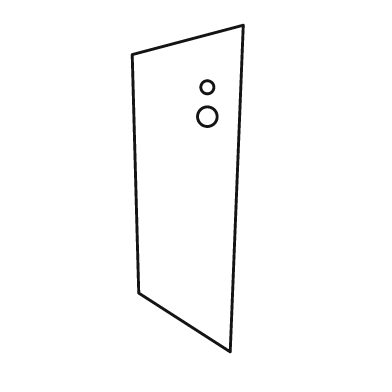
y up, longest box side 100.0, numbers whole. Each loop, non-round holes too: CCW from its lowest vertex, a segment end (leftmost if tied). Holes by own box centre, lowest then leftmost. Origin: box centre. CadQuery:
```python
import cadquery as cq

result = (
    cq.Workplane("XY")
    .moveTo(13.0, -50.0)
    .lineTo(17.0, 50.0)
    .lineTo(-17.0, 41.0)
    .lineTo(-15.0, -32.0)
    .close()
    .moveTo(6.0, 22.0)
    .circle(3.0)
    .moveTo(6.0, 31.0)
    .circle(2.0)
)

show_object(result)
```